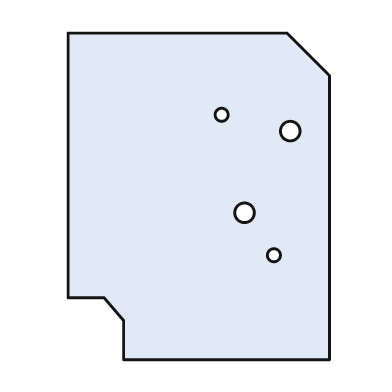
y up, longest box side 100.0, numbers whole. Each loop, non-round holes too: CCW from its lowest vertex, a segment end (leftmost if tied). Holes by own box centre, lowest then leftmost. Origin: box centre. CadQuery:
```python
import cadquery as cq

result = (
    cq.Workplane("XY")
    .moveTo(-23.0, -50.0)
    .lineTo(40.0, -50.0)
    .lineTo(40.0, 37.0)
    .lineTo(27.0, 50.0)
    .lineTo(-40.0, 50.0)
    .lineTo(-40.0, -31.0)
    .lineTo(-29.0, -31.0)
    .lineTo(-23.0, -38.0)
    .close()
    .moveTo(23.0, -18.0)
    .circle(2.0)
    .moveTo(14.0, -5.0)
    .circle(3.0)
    .moveTo(28.0, 20.0)
    .circle(3.0)
    .moveTo(7.0, 25.0)
    .circle(2.0)
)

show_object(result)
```